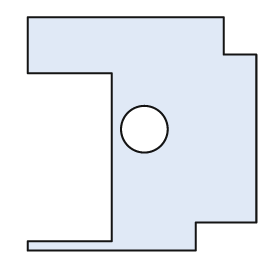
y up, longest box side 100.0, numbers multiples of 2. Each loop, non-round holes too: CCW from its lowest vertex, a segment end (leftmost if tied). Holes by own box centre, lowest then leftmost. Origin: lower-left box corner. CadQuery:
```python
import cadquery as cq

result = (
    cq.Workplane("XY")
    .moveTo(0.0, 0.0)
    .lineTo(72.0, 0.0)
    .lineTo(72.0, 12.0)
    .lineTo(98.0, 12.0)
    .lineTo(98.0, 84.0)
    .lineTo(84.0, 84.0)
    .lineTo(84.0, 100.0)
    .lineTo(0.0, 100.0)
    .lineTo(0.0, 76.0)
    .lineTo(36.0, 76.0)
    .lineTo(36.0, 4.0)
    .lineTo(0.0, 4.0)
    .close()
    .moveTo(50.0, 52.0)
    .circle(10.0)
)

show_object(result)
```